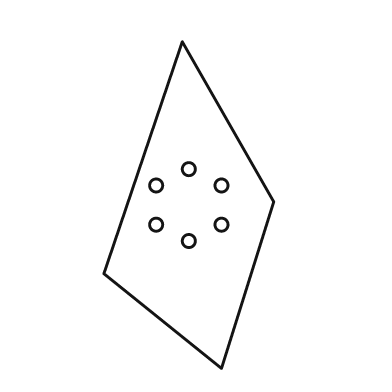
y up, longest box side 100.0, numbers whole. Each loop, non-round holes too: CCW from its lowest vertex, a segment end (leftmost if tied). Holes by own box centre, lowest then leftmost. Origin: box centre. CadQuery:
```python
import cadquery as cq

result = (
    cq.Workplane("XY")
    .moveTo(10.0, -50.0)
    .lineTo(26.0, 1.0)
    .lineTo(-2.0, 50.0)
    .lineTo(-26.0, -21.0)
    .close()
    .moveTo(0.0, -11.0)
    .circle(2.0)
    .moveTo(-10.0, -6.0)
    .circle(2.0)
    .moveTo(10.0, -6.0)
    .circle(2.0)
    .moveTo(-10.0, 6.0)
    .circle(2.0)
    .moveTo(10.0, 6.0)
    .circle(2.0)
    .moveTo(0.0, 11.0)
    .circle(2.0)
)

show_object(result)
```